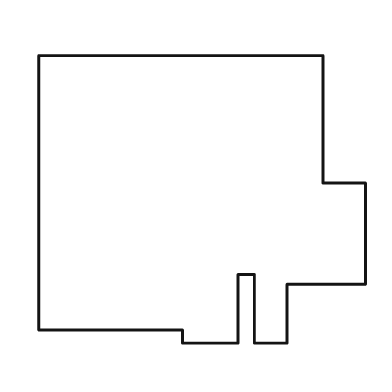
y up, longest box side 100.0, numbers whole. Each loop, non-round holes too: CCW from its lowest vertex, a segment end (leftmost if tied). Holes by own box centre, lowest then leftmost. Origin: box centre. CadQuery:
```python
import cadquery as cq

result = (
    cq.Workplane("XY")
    .moveTo(-6.0, -44.0)
    .lineTo(11.0, -44.0)
    .lineTo(11.0, -23.0)
    .lineTo(16.0, -23.0)
    .lineTo(16.0, -44.0)
    .lineTo(26.0, -44.0)
    .lineTo(26.0, -26.0)
    .lineTo(50.0, -26.0)
    .lineTo(50.0, 5.0)
    .lineTo(37.0, 5.0)
    .lineTo(37.0, 44.0)
    .lineTo(-50.0, 44.0)
    .lineTo(-50.0, -40.0)
    .lineTo(-6.0, -40.0)
    .close()
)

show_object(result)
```